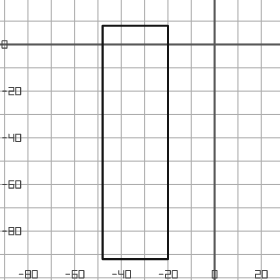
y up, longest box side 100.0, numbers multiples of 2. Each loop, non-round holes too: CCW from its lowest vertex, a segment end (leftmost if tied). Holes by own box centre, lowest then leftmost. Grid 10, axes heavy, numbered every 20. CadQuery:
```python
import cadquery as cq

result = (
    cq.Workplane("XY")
    .moveTo(-48.0, -92.0)
    .lineTo(-20.0, -92.0)
    .lineTo(-20.0, 8.0)
    .lineTo(-48.0, 8.0)
    .close()
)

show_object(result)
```